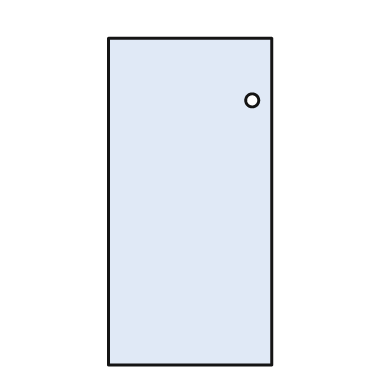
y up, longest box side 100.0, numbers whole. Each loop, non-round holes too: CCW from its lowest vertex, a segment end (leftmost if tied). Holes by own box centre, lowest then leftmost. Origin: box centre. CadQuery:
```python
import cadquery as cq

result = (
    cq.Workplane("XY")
    .moveTo(-25.0, -50.0)
    .lineTo(25.0, -50.0)
    .lineTo(25.0, 50.0)
    .lineTo(-25.0, 50.0)
    .close()
    .moveTo(19.0, 31.0)
    .circle(2.0)
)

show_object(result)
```